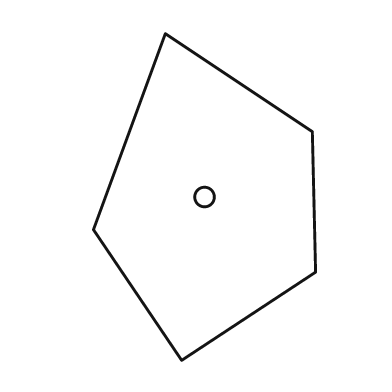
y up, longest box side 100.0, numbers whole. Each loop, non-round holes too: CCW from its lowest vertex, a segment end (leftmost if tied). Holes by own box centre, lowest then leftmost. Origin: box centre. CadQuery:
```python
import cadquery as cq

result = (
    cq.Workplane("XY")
    .moveTo(-7.0, -50.0)
    .lineTo(34.0, -23.0)
    .lineTo(33.0, 20.0)
    .lineTo(-12.0, 50.0)
    .lineTo(-34.0, -10.0)
    .close()
    .moveTo(0.0, 0.0)
    .circle(3.0)
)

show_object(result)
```